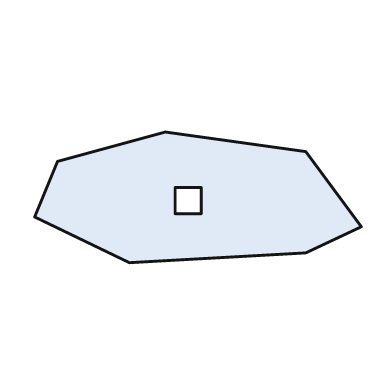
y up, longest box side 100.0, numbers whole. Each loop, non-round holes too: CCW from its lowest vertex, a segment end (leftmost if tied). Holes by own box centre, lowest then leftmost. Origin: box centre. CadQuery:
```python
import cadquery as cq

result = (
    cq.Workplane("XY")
    .moveTo(-21.0, -20.0)
    .lineTo(33.0, -17.0)
    .lineTo(50.0, -9.0)
    .lineTo(33.0, 14.0)
    .lineTo(-10.0, 20.0)
    .lineTo(-43.0, 11.0)
    .lineTo(-50.0, -6.0)
    .close()
    .moveTo(-7.0, -5.0)
    .lineTo(1.0, -5.0)
    .lineTo(1.0, 3.0)
    .lineTo(-7.0, 3.0)
    .close()
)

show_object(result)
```